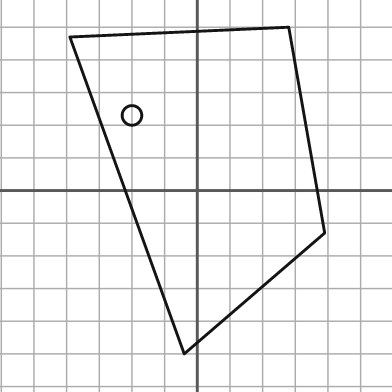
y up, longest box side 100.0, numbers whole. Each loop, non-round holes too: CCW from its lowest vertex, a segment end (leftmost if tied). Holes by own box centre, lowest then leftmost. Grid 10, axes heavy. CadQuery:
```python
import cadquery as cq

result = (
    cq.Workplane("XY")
    .moveTo(-4.0, -50.0)
    .lineTo(39.0, -13.0)
    .lineTo(28.0, 50.0)
    .lineTo(-39.0, 47.0)
    .close()
    .moveTo(-20.0, 23.0)
    .circle(3.0)
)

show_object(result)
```